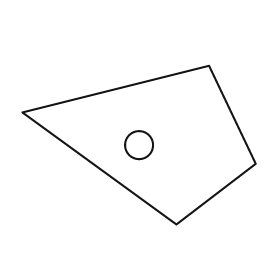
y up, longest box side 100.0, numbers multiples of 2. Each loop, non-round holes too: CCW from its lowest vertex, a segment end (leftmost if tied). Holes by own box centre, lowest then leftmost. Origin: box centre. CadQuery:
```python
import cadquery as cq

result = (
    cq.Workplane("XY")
    .moveTo(16.0, -34.0)
    .lineTo(50.0, -8.0)
    .lineTo(30.0, 34.0)
    .lineTo(-50.0, 14.0)
    .close()
    .moveTo(0.0, 0.0)
    .circle(6.0)
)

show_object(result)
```